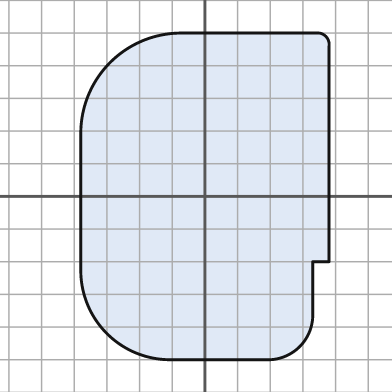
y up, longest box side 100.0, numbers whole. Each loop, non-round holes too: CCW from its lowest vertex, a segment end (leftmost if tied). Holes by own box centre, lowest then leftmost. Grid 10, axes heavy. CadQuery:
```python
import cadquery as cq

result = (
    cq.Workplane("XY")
    .moveTo(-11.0, -50.0)
    .lineTo(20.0, -50.0)
    .threePointArc((29.0, -46.0), (33.0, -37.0))
    .lineTo(33.0, -20.0)
    .lineTo(38.0, -20.0)
    .lineTo(38.0, 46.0)
    .threePointArc((37.0, 49.0), (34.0, 50.0))
    .lineTo(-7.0, 50.0)
    .threePointArc((-29.0, 41.0), (-38.0, 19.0))
    .lineTo(-38.0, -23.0)
    .threePointArc((-30.0, -42.0), (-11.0, -50.0))
    .close()
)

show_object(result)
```